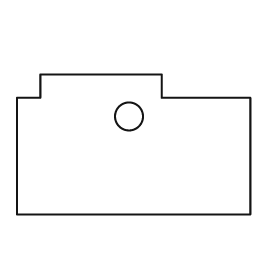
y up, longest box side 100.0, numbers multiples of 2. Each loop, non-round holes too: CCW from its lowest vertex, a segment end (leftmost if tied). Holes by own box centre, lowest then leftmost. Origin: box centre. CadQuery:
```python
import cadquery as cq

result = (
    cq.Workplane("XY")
    .moveTo(-50.0, -30.0)
    .lineTo(50.0, -30.0)
    .lineTo(50.0, 20.0)
    .lineTo(12.0, 20.0)
    .lineTo(12.0, 30.0)
    .lineTo(-40.0, 30.0)
    .lineTo(-40.0, 20.0)
    .lineTo(-50.0, 20.0)
    .close()
    .moveTo(-2.0, 12.0)
    .circle(6.0)
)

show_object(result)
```